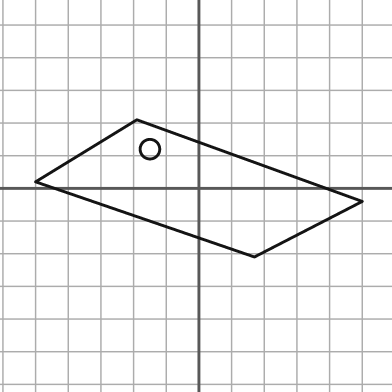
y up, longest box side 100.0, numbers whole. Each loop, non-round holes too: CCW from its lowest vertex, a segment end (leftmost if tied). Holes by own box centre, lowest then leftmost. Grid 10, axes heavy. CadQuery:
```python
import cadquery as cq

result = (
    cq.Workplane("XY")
    .moveTo(17.0, -21.0)
    .lineTo(50.0, -4.0)
    .lineTo(-19.0, 21.0)
    .lineTo(-50.0, 2.0)
    .close()
    .moveTo(-15.0, 12.0)
    .circle(3.0)
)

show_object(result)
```